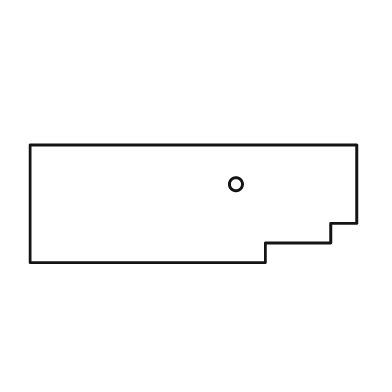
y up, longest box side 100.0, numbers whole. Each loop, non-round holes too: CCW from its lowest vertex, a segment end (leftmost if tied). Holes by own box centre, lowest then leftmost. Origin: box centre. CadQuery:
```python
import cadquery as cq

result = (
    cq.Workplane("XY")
    .moveTo(-50.0, -18.0)
    .lineTo(22.0, -18.0)
    .lineTo(22.0, -12.0)
    .lineTo(42.0, -12.0)
    .lineTo(42.0, -6.0)
    .lineTo(50.0, -6.0)
    .lineTo(50.0, 18.0)
    .lineTo(-50.0, 18.0)
    .close()
    .moveTo(13.0, 6.0)
    .circle(2.0)
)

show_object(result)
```